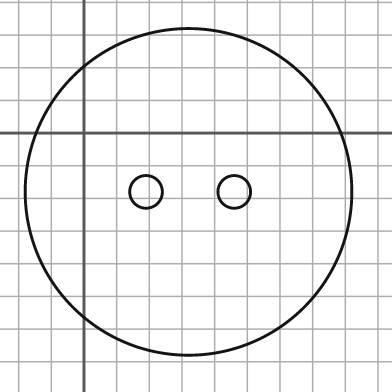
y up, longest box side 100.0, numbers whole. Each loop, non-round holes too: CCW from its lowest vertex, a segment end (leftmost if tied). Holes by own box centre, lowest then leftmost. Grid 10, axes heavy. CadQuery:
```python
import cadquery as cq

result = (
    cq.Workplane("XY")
    .moveTo(32.0, -18.0)
    .circle(50.0)
    .moveTo(19.0, -18.0)
    .circle(5.0)
    .moveTo(46.0, -18.0)
    .circle(5.0)
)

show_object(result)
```